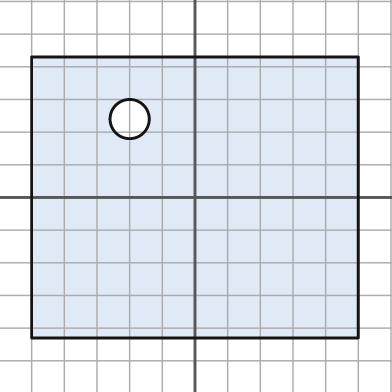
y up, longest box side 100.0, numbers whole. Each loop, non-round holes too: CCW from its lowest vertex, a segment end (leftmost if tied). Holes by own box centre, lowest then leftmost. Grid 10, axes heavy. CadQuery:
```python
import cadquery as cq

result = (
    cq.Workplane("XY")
    .moveTo(-50.0, -43.0)
    .lineTo(50.0, -43.0)
    .lineTo(50.0, 43.0)
    .lineTo(-50.0, 43.0)
    .close()
    .moveTo(-20.0, 24.0)
    .circle(6.0)
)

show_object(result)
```